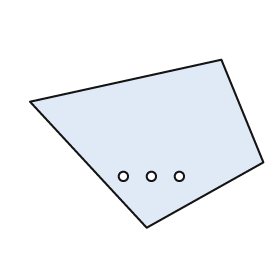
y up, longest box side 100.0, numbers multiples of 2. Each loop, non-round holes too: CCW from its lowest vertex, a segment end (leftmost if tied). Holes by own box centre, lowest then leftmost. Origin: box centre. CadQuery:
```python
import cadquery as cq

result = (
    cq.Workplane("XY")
    .moveTo(0.0, -36.0)
    .lineTo(50.0, -8.0)
    .lineTo(32.0, 36.0)
    .lineTo(-50.0, 18.0)
    .close()
    .moveTo(-10.0, -14.0)
    .circle(2.0)
    .moveTo(2.0, -14.0)
    .circle(2.0)
    .moveTo(14.0, -14.0)
    .circle(2.0)
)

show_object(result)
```